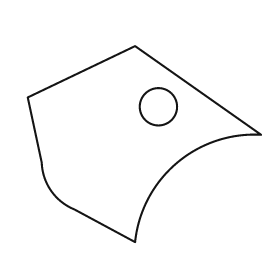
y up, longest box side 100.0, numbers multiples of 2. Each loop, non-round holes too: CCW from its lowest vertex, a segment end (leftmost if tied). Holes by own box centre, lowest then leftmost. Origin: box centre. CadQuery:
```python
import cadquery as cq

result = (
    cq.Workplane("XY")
    .moveTo(-4.0, -42.0)
    .threePointArc((14.0, -8.0), (50.0, 4.0))
    .lineTo(-4.0, 42.0)
    .lineTo(-50.0, 20.0)
    .lineTo(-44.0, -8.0)
    .threePointArc((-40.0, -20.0), (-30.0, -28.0))
    .close()
    .moveTo(6.0, 16.0)
    .circle(8.0)
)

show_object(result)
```